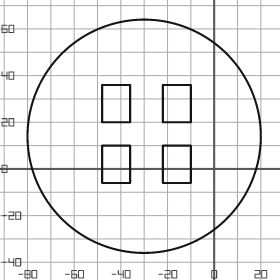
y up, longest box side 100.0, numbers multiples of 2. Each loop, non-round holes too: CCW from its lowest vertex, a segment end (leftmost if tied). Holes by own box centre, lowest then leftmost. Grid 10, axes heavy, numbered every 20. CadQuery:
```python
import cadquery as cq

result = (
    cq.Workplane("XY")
    .moveTo(-30.0, 14.0)
    .circle(50.0)
    .moveTo(-48.0, -6.0)
    .lineTo(-36.0, -6.0)
    .lineTo(-36.0, 10.0)
    .lineTo(-48.0, 10.0)
    .close()
    .moveTo(-22.0, -6.0)
    .lineTo(-10.0, -6.0)
    .lineTo(-10.0, 10.0)
    .lineTo(-22.0, 10.0)
    .close()
    .moveTo(-48.0, 20.0)
    .lineTo(-36.0, 20.0)
    .lineTo(-36.0, 36.0)
    .lineTo(-48.0, 36.0)
    .close()
    .moveTo(-22.0, 20.0)
    .lineTo(-10.0, 20.0)
    .lineTo(-10.0, 36.0)
    .lineTo(-22.0, 36.0)
    .close()
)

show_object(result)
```